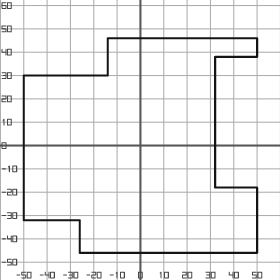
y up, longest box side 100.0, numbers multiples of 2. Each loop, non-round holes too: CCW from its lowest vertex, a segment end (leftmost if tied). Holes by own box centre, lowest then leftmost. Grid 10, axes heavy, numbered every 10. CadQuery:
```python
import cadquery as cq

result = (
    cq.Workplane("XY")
    .moveTo(-26.0, -46.0)
    .lineTo(50.0, -46.0)
    .lineTo(50.0, -18.0)
    .lineTo(32.0, -18.0)
    .lineTo(32.0, 38.0)
    .lineTo(50.0, 38.0)
    .lineTo(50.0, 46.0)
    .lineTo(-14.0, 46.0)
    .lineTo(-14.0, 30.0)
    .lineTo(-50.0, 30.0)
    .lineTo(-50.0, -32.0)
    .lineTo(-26.0, -32.0)
    .close()
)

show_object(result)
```